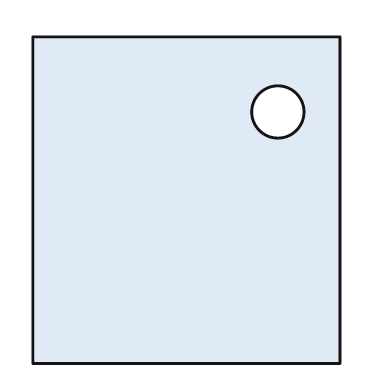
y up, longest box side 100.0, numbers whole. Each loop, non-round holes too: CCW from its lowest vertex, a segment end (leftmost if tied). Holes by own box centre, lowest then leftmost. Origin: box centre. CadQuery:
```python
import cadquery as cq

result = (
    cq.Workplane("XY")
    .moveTo(-47.0, -50.0)
    .lineTo(47.0, -50.0)
    .lineTo(47.0, 50.0)
    .lineTo(-47.0, 50.0)
    .close()
    .moveTo(28.0, 27.0)
    .circle(8.0)
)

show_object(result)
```